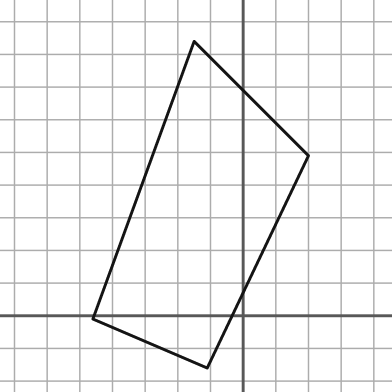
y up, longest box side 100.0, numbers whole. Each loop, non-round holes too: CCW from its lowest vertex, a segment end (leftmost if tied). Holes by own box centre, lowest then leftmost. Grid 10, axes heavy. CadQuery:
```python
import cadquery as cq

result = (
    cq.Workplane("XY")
    .moveTo(-11.0, -16.0)
    .lineTo(20.0, 49.0)
    .lineTo(-15.0, 84.0)
    .lineTo(-46.0, -1.0)
    .close()
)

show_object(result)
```